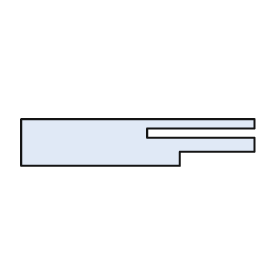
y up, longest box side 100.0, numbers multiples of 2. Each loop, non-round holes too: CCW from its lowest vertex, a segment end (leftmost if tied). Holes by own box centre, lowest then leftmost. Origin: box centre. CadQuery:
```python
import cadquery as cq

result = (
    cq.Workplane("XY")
    .moveTo(-50.0, -10.0)
    .lineTo(18.0, -10.0)
    .lineTo(18.0, -4.0)
    .lineTo(50.0, -4.0)
    .lineTo(50.0, 2.0)
    .lineTo(4.0, 2.0)
    .lineTo(4.0, 6.0)
    .lineTo(50.0, 6.0)
    .lineTo(50.0, 10.0)
    .lineTo(-50.0, 10.0)
    .close()
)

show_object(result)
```